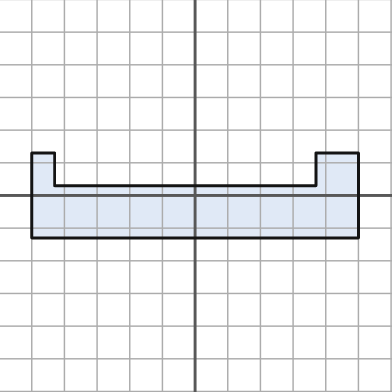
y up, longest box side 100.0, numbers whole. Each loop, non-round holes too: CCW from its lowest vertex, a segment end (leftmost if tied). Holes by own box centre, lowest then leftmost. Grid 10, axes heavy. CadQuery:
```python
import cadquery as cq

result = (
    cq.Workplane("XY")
    .moveTo(-50.0, -13.0)
    .lineTo(50.0, -13.0)
    .lineTo(50.0, 13.0)
    .lineTo(37.0, 13.0)
    .lineTo(37.0, 3.0)
    .lineTo(-43.0, 3.0)
    .lineTo(-43.0, 13.0)
    .lineTo(-50.0, 13.0)
    .close()
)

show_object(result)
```